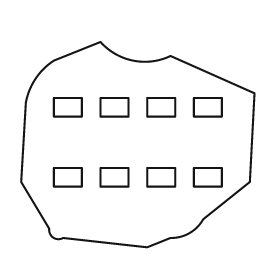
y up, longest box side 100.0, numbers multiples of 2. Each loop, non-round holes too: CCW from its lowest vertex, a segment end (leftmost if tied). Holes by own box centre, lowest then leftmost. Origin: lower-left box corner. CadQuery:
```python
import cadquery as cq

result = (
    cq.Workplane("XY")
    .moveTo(54.0, 0.0)
    .lineTo(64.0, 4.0)
    .threePointArc((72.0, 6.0), (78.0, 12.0))
    .lineTo(98.0, 28.0)
    .lineTo(100.0, 66.0)
    .lineTo(64.0, 82.0)
    .threePointArc((48.0, 80.0), (34.0, 88.0))
    .lineTo(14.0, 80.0)
    .threePointArc((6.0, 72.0), (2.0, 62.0))
    .lineTo(0.0, 28.0)
    .lineTo(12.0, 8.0)
    .threePointArc((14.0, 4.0), (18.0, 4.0))
    .close()
    .moveTo(14.0, 26.0)
    .lineTo(26.0, 26.0)
    .lineTo(26.0, 34.0)
    .lineTo(14.0, 34.0)
    .close()
    .moveTo(34.0, 26.0)
    .lineTo(46.0, 26.0)
    .lineTo(46.0, 34.0)
    .lineTo(34.0, 34.0)
    .close()
    .moveTo(54.0, 26.0)
    .lineTo(66.0, 26.0)
    .lineTo(66.0, 34.0)
    .lineTo(54.0, 34.0)
    .close()
    .moveTo(74.0, 26.0)
    .lineTo(86.0, 26.0)
    .lineTo(86.0, 34.0)
    .lineTo(74.0, 34.0)
    .close()
    .moveTo(14.0, 56.0)
    .lineTo(26.0, 56.0)
    .lineTo(26.0, 64.0)
    .lineTo(14.0, 64.0)
    .close()
    .moveTo(34.0, 56.0)
    .lineTo(46.0, 56.0)
    .lineTo(46.0, 64.0)
    .lineTo(34.0, 64.0)
    .close()
    .moveTo(54.0, 56.0)
    .lineTo(66.0, 56.0)
    .lineTo(66.0, 64.0)
    .lineTo(54.0, 64.0)
    .close()
    .moveTo(74.0, 56.0)
    .lineTo(86.0, 56.0)
    .lineTo(86.0, 64.0)
    .lineTo(74.0, 64.0)
    .close()
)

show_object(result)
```